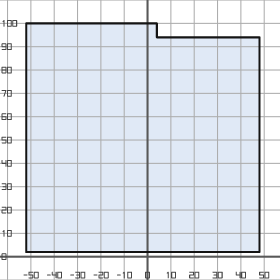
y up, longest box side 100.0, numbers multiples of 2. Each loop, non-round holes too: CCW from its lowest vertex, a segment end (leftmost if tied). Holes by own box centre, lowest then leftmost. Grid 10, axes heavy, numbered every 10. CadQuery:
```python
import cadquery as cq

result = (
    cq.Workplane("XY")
    .moveTo(-52.0, 2.0)
    .lineTo(48.0, 2.0)
    .lineTo(48.0, 94.0)
    .lineTo(4.0, 94.0)
    .lineTo(4.0, 100.0)
    .lineTo(-52.0, 100.0)
    .close()
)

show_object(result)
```